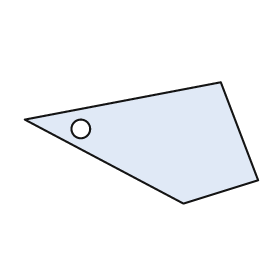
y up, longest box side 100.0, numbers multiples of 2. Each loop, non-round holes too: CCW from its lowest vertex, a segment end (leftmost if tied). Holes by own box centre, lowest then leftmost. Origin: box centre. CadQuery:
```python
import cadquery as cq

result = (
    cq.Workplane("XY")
    .moveTo(18.0, -26.0)
    .lineTo(50.0, -16.0)
    .lineTo(34.0, 26.0)
    .lineTo(-50.0, 10.0)
    .close()
    .moveTo(-26.0, 6.0)
    .circle(4.0)
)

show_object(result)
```